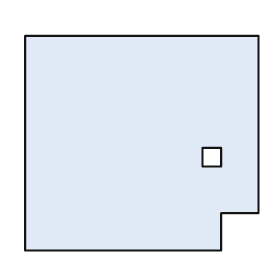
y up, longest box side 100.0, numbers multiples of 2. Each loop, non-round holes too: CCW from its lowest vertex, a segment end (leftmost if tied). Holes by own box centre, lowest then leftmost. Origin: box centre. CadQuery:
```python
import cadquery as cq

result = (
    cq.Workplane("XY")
    .moveTo(-50.0, -46.0)
    .lineTo(34.0, -46.0)
    .lineTo(34.0, -30.0)
    .lineTo(50.0, -30.0)
    .lineTo(50.0, 46.0)
    .lineTo(-50.0, 46.0)
    .close()
    .moveTo(26.0, -10.0)
    .lineTo(34.0, -10.0)
    .lineTo(34.0, -2.0)
    .lineTo(26.0, -2.0)
    .close()
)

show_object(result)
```